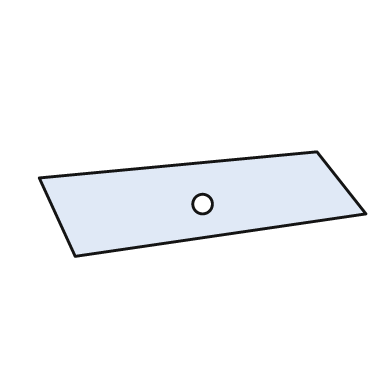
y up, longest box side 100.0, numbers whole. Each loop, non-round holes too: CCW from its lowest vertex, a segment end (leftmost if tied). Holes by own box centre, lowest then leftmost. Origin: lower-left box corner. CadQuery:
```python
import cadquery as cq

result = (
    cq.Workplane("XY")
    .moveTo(11.0, 0.0)
    .lineTo(100.0, 13.0)
    .lineTo(85.0, 32.0)
    .lineTo(0.0, 24.0)
    .close()
    .moveTo(50.0, 16.0)
    .circle(3.0)
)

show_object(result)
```